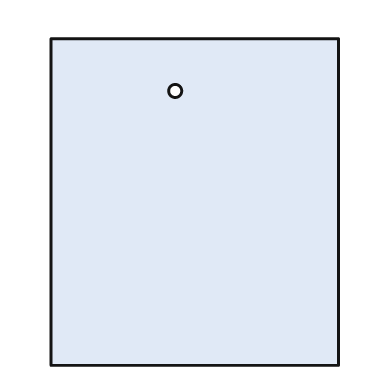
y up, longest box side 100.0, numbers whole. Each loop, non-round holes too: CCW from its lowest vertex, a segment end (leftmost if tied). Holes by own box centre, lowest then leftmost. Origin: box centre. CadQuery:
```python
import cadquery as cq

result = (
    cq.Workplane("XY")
    .moveTo(-44.0, -50.0)
    .lineTo(44.0, -50.0)
    .lineTo(44.0, 50.0)
    .lineTo(-44.0, 50.0)
    .close()
    .moveTo(-6.0, 34.0)
    .circle(2.0)
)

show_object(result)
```